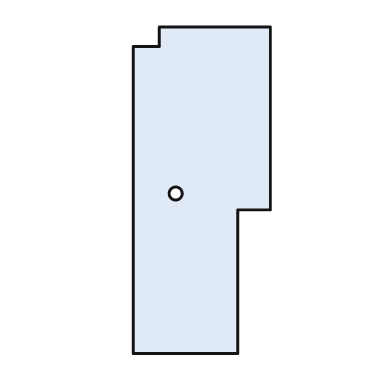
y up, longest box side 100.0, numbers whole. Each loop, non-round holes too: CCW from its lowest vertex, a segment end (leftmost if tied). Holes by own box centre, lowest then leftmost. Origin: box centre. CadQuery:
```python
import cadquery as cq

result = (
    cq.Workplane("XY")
    .moveTo(-21.0, -50.0)
    .lineTo(11.0, -50.0)
    .lineTo(11.0, -6.0)
    .lineTo(21.0, -6.0)
    .lineTo(21.0, 50.0)
    .lineTo(-13.0, 50.0)
    .lineTo(-13.0, 44.0)
    .lineTo(-21.0, 44.0)
    .close()
    .moveTo(-8.0, -1.0)
    .circle(2.0)
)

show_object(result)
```